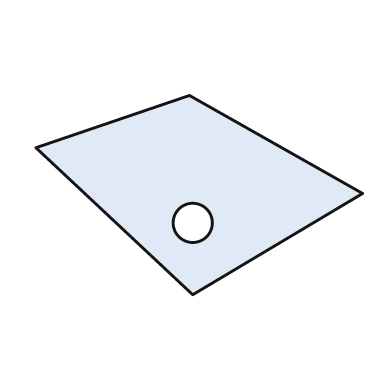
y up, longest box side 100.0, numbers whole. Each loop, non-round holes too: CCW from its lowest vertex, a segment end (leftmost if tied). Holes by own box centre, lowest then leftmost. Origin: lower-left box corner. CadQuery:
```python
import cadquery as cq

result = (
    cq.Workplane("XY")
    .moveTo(48.0, 0.0)
    .lineTo(100.0, 31.0)
    .lineTo(47.0, 61.0)
    .lineTo(0.0, 45.0)
    .close()
    .moveTo(48.0, 22.0)
    .circle(6.0)
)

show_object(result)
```